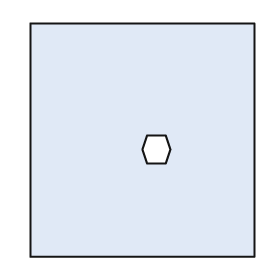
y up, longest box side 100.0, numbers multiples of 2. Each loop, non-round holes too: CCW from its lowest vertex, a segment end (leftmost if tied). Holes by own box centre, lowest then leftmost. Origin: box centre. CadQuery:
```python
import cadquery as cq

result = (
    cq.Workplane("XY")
    .moveTo(-48.0, -50.0)
    .lineTo(48.0, -50.0)
    .lineTo(48.0, 50.0)
    .lineTo(-48.0, 50.0)
    .close()
    .moveTo(2.0, -10.0)
    .lineTo(10.0, -10.0)
    .lineTo(12.0, -4.0)
    .lineTo(10.0, 2.0)
    .lineTo(2.0, 2.0)
    .lineTo(0.0, -4.0)
    .close()
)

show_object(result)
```